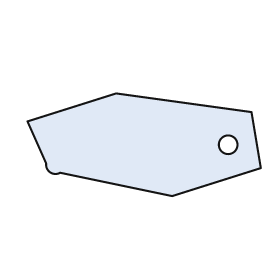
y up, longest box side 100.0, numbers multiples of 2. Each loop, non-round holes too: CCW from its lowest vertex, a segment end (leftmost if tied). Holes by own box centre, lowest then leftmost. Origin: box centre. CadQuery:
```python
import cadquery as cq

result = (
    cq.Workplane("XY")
    .moveTo(12.0, -22.0)
    .lineTo(50.0, -10.0)
    .lineTo(46.0, 14.0)
    .lineTo(-12.0, 22.0)
    .lineTo(-50.0, 10.0)
    .lineTo(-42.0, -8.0)
    .threePointArc((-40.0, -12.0), (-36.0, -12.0))
    .close()
    .moveTo(36.0, 0.0)
    .circle(4.0)
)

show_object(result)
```